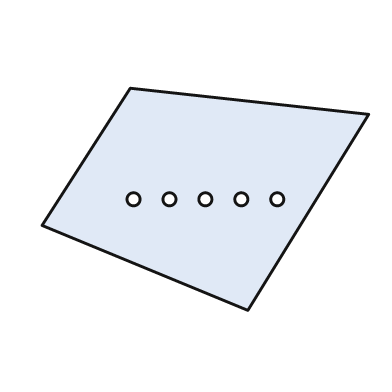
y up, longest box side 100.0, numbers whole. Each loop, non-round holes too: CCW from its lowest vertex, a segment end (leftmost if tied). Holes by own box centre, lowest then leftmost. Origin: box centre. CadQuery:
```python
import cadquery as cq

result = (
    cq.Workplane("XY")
    .moveTo(13.0, -34.0)
    .lineTo(50.0, 26.0)
    .lineTo(-23.0, 34.0)
    .lineTo(-50.0, -8.0)
    .close()
    .moveTo(-22.0, 0.0)
    .circle(2.0)
    .moveTo(-11.0, 0.0)
    .circle(2.0)
    .moveTo(0.0, 0.0)
    .circle(2.0)
    .moveTo(11.0, 0.0)
    .circle(2.0)
    .moveTo(22.0, 0.0)
    .circle(2.0)
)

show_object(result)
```